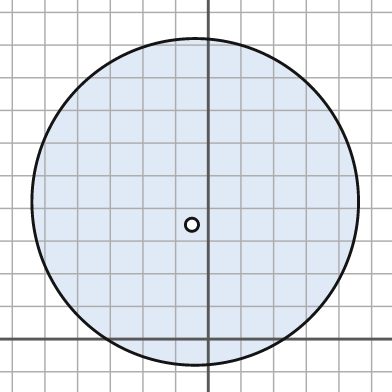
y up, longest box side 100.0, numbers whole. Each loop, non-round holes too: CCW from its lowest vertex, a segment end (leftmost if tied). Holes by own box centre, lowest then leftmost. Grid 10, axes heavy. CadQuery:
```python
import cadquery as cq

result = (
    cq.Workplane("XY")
    .moveTo(-4.0, 42.0)
    .circle(50.0)
    .moveTo(-5.0, 35.0)
    .circle(2.0)
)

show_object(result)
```